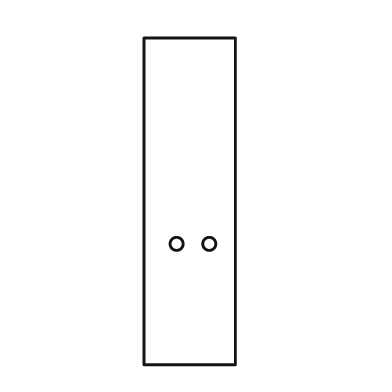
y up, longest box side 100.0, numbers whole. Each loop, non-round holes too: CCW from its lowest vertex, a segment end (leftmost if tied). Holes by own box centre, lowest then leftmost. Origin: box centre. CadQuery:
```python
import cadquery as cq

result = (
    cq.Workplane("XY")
    .moveTo(-14.0, -50.0)
    .lineTo(14.0, -50.0)
    .lineTo(14.0, 50.0)
    .lineTo(-14.0, 50.0)
    .close()
    .moveTo(-4.0, -13.0)
    .circle(2.0)
    .moveTo(6.0, -13.0)
    .circle(2.0)
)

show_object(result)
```